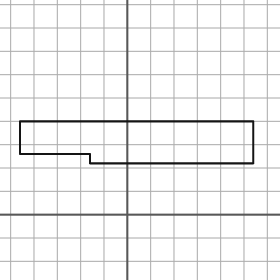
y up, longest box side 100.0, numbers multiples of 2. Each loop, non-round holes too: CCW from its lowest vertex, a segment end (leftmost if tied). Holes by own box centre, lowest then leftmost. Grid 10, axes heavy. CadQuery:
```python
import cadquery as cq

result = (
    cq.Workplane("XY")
    .moveTo(-16.0, 22.0)
    .lineTo(54.0, 22.0)
    .lineTo(54.0, 40.0)
    .lineTo(-46.0, 40.0)
    .lineTo(-46.0, 26.0)
    .lineTo(-16.0, 26.0)
    .close()
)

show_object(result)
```